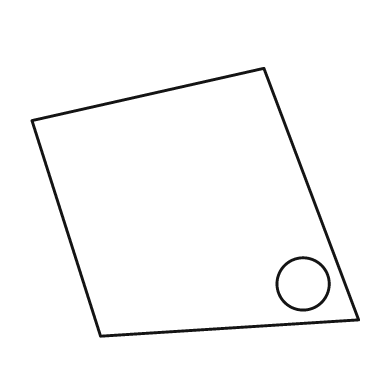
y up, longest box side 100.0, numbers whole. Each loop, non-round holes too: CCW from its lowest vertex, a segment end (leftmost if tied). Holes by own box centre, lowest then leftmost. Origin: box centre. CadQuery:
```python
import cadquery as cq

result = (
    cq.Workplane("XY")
    .moveTo(-29.0, -41.0)
    .lineTo(50.0, -36.0)
    .lineTo(21.0, 41.0)
    .lineTo(-50.0, 25.0)
    .close()
    .moveTo(33.0, -25.0)
    .circle(8.0)
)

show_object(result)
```